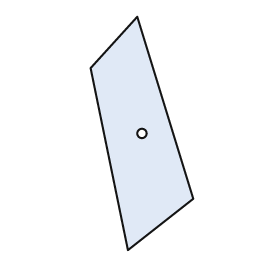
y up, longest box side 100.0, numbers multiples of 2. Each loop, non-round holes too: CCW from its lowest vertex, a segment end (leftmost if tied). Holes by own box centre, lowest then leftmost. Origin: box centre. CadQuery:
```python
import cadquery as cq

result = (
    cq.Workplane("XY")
    .moveTo(-6.0, -50.0)
    .lineTo(22.0, -28.0)
    .lineTo(-2.0, 50.0)
    .lineTo(-22.0, 28.0)
    .close()
    .moveTo(0.0, 0.0)
    .circle(2.0)
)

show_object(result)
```